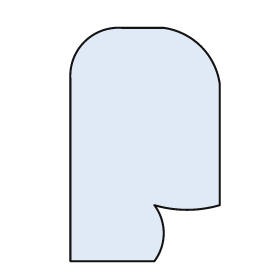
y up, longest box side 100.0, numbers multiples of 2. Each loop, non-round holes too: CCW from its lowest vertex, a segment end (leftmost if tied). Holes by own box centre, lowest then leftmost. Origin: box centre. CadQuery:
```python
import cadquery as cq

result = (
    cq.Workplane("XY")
    .moveTo(-32.0, -50.0)
    .lineTo(4.0, -50.0)
    .threePointArc((8.0, -38.0), (4.0, -26.0))
    .threePointArc((18.0, -28.0), (32.0, -26.0))
    .lineTo(32.0, 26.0)
    .threePointArc((24.0, 42.0), (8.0, 50.0))
    .lineTo(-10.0, 50.0)
    .threePointArc((-26.0, 44.0), (-32.0, 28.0))
    .close()
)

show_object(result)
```